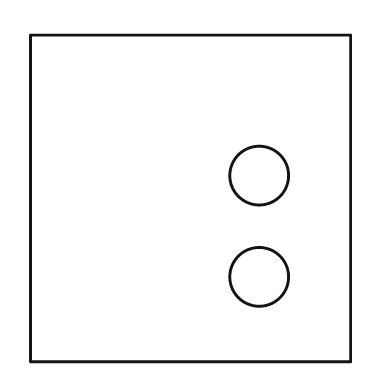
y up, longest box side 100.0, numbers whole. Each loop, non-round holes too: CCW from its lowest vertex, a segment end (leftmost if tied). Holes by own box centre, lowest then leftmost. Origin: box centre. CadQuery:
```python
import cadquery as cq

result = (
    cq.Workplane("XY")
    .moveTo(-49.0, -50.0)
    .lineTo(49.0, -50.0)
    .lineTo(49.0, 50.0)
    .lineTo(-49.0, 50.0)
    .close()
    .moveTo(21.0, -24.0)
    .circle(9.0)
    .moveTo(21.0, 7.0)
    .circle(9.0)
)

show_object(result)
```